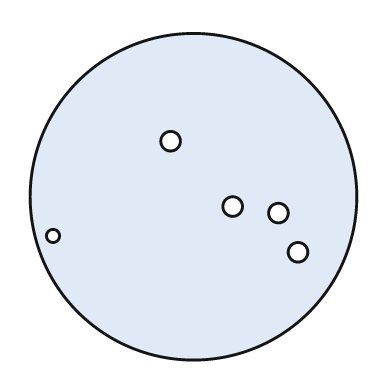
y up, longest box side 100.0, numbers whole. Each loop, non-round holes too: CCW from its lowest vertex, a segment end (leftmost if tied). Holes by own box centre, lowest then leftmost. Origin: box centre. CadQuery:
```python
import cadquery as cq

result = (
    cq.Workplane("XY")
    .moveTo(0.0, 0.0)
    .circle(50.0)
    .moveTo(32.0, -17.0)
    .circle(3.0)
    .moveTo(-43.0, -12.0)
    .circle(2.0)
    .moveTo(26.0, -5.0)
    .circle(3.0)
    .moveTo(12.0, -3.0)
    .circle(3.0)
    .moveTo(-7.0, 17.0)
    .circle(3.0)
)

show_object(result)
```